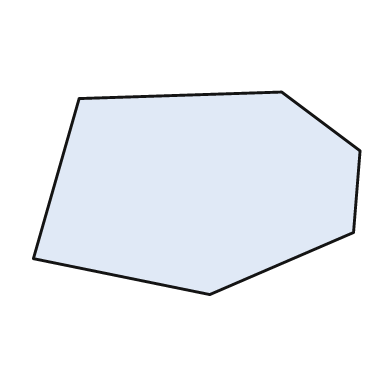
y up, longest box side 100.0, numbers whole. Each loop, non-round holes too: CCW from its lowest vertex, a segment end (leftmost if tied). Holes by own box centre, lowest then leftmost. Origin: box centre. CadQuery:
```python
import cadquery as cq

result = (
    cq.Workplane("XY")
    .moveTo(4.0, -31.0)
    .lineTo(48.0, -12.0)
    .lineTo(50.0, 13.0)
    .lineTo(26.0, 31.0)
    .lineTo(-36.0, 29.0)
    .lineTo(-50.0, -20.0)
    .close()
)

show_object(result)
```